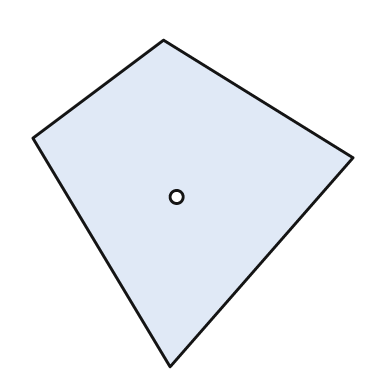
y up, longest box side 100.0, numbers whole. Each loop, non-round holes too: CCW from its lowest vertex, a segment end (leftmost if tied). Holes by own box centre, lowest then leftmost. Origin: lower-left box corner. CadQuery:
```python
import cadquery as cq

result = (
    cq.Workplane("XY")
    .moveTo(42.0, 0.0)
    .lineTo(98.0, 64.0)
    .lineTo(40.0, 100.0)
    .lineTo(0.0, 70.0)
    .close()
    .moveTo(44.0, 52.0)
    .circle(2.0)
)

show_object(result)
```